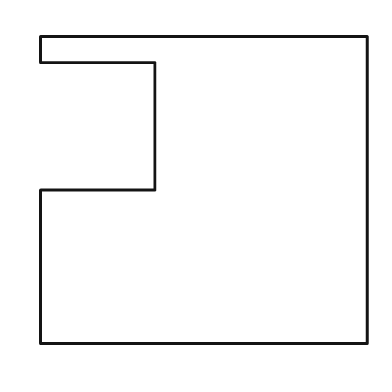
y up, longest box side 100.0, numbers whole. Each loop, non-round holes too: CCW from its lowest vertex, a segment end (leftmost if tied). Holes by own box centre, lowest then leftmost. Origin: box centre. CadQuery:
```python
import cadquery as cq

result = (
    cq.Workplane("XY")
    .moveTo(-50.0, -47.0)
    .lineTo(50.0, -47.0)
    .lineTo(50.0, 47.0)
    .lineTo(-50.0, 47.0)
    .lineTo(-50.0, 39.0)
    .lineTo(-15.0, 39.0)
    .lineTo(-15.0, 0.0)
    .lineTo(-50.0, 0.0)
    .close()
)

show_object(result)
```